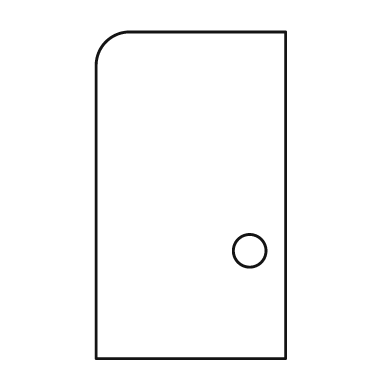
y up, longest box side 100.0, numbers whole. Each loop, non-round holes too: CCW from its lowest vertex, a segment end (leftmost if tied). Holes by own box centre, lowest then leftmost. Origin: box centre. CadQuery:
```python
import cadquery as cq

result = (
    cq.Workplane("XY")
    .moveTo(-29.0, -50.0)
    .lineTo(29.0, -50.0)
    .lineTo(29.0, 50.0)
    .lineTo(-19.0, 50.0)
    .threePointArc((-26.0, 47.0), (-29.0, 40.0))
    .close()
    .moveTo(18.0, -17.0)
    .circle(5.0)
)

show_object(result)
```